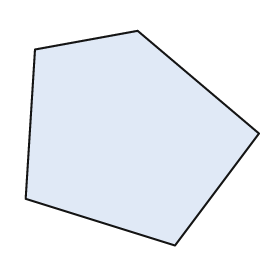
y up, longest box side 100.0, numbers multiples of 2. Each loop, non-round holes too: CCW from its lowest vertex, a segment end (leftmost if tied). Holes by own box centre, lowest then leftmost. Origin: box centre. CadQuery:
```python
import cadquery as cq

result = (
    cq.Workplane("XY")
    .moveTo(14.0, -46.0)
    .lineTo(50.0, 2.0)
    .lineTo(-2.0, 46.0)
    .lineTo(-46.0, 38.0)
    .lineTo(-50.0, -26.0)
    .close()
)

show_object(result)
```